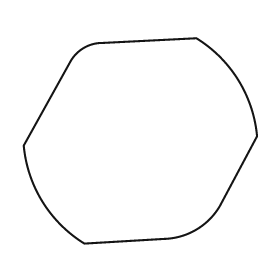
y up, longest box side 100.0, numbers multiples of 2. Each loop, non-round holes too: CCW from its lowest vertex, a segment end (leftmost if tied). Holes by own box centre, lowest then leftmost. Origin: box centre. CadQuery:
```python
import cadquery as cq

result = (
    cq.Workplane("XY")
    .moveTo(-24.0, -44.0)
    .lineTo(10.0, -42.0)
    .threePointArc((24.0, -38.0), (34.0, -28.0))
    .lineTo(50.0, 2.0)
    .threePointArc((42.0, 26.0), (24.0, 44.0))
    .lineTo(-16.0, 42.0)
    .threePointArc((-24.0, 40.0), (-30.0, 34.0))
    .lineTo(-50.0, -2.0)
    .threePointArc((-42.0, -26.0), (-24.0, -44.0))
    .close()
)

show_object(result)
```